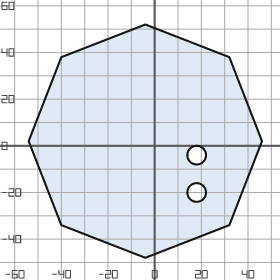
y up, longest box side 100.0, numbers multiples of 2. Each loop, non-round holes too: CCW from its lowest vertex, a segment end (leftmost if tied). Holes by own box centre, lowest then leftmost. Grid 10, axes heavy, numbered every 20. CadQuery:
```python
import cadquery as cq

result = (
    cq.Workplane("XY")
    .moveTo(-4.0, -48.0)
    .lineTo(32.0, -34.0)
    .lineTo(46.0, 2.0)
    .lineTo(32.0, 38.0)
    .lineTo(-4.0, 52.0)
    .lineTo(-40.0, 38.0)
    .lineTo(-54.0, 2.0)
    .lineTo(-40.0, -34.0)
    .close()
    .moveTo(18.0, -20.0)
    .circle(4.0)
    .moveTo(18.0, -4.0)
    .circle(4.0)
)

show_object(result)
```